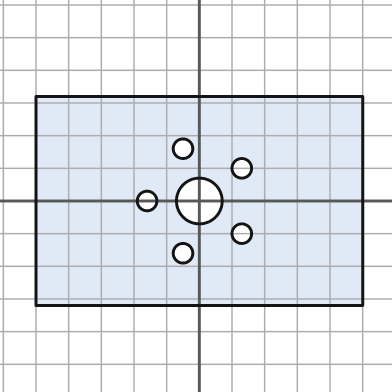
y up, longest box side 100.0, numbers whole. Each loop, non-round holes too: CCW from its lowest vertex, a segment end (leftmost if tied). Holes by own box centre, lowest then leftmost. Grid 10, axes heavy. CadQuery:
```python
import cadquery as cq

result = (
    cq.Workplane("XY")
    .moveTo(-50.0, -32.0)
    .lineTo(50.0, -32.0)
    .lineTo(50.0, 32.0)
    .lineTo(-50.0, 32.0)
    .close()
    .moveTo(-5.0, -16.0)
    .circle(3.0)
    .moveTo(13.0, -10.0)
    .circle(3.0)
    .moveTo(-16.0, 0.0)
    .circle(3.0)
    .moveTo(0.0, 0.0)
    .circle(7.0)
    .moveTo(13.0, 10.0)
    .circle(3.0)
    .moveTo(-5.0, 16.0)
    .circle(3.0)
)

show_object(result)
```